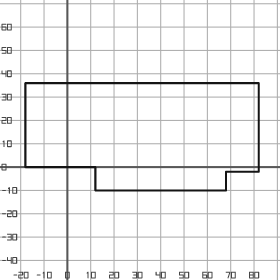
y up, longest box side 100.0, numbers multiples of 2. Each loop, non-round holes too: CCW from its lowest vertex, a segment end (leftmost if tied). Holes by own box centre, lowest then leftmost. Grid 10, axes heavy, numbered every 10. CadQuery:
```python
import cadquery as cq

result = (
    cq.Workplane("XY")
    .moveTo(12.0, -10.0)
    .lineTo(68.0, -10.0)
    .lineTo(68.0, -2.0)
    .lineTo(82.0, -2.0)
    .lineTo(82.0, 36.0)
    .lineTo(-18.0, 36.0)
    .lineTo(-18.0, 0.0)
    .lineTo(12.0, 0.0)
    .close()
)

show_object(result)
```